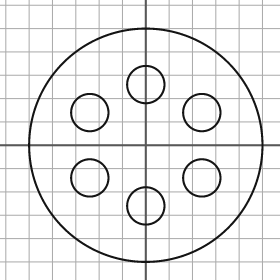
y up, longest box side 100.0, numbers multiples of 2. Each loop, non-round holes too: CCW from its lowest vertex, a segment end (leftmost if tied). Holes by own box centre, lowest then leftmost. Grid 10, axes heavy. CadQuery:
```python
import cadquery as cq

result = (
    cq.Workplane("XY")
    .moveTo(0.0, 0.0)
    .circle(50.0)
    .moveTo(0.0, -26.0)
    .circle(8.0)
    .moveTo(-24.0, -14.0)
    .circle(8.0)
    .moveTo(24.0, -14.0)
    .circle(8.0)
    .moveTo(-24.0, 14.0)
    .circle(8.0)
    .moveTo(24.0, 14.0)
    .circle(8.0)
    .moveTo(0.0, 26.0)
    .circle(8.0)
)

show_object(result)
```